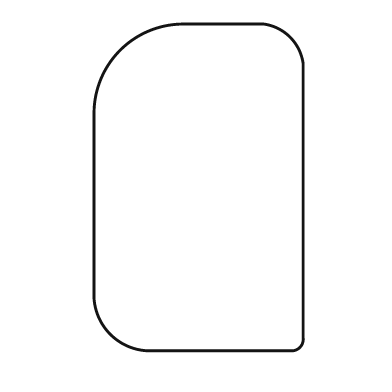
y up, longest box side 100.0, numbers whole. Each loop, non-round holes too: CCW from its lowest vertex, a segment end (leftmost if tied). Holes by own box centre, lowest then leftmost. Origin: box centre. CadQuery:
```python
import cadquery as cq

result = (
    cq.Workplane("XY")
    .moveTo(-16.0, -50.0)
    .lineTo(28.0, -50.0)
    .threePointArc((31.0, -49.0), (32.0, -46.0))
    .lineTo(32.0, 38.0)
    .threePointArc((28.0, 46.0), (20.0, 50.0))
    .lineTo(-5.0, 50.0)
    .threePointArc((-24.0, 42.0), (-32.0, 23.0))
    .lineTo(-32.0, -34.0)
    .threePointArc((-27.0, -45.0), (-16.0, -50.0))
    .close()
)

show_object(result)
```